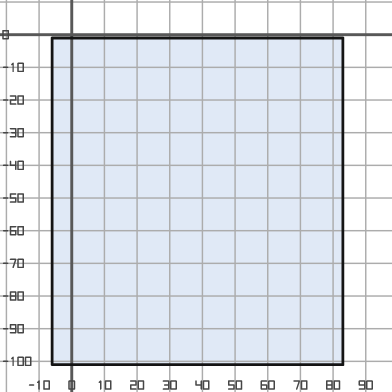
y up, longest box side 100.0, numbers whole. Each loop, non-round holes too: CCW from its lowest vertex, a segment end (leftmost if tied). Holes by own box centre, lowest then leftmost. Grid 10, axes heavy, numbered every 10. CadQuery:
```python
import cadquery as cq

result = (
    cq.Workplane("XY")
    .moveTo(-6.0, -101.0)
    .lineTo(83.0, -101.0)
    .lineTo(83.0, -1.0)
    .lineTo(-6.0, -1.0)
    .close()
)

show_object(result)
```